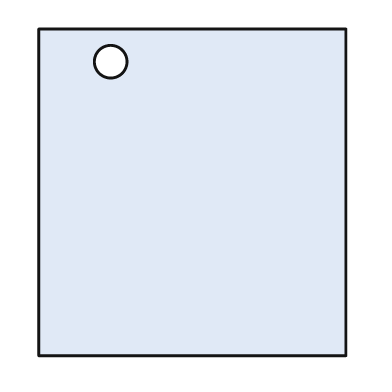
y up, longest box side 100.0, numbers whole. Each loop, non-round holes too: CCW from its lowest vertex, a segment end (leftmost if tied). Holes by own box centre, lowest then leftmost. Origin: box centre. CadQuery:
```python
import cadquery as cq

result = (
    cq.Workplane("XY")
    .moveTo(-47.0, -50.0)
    .lineTo(47.0, -50.0)
    .lineTo(47.0, 50.0)
    .lineTo(-47.0, 50.0)
    .close()
    .moveTo(-25.0, 40.0)
    .circle(5.0)
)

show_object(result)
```